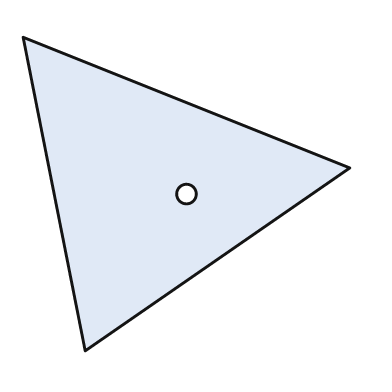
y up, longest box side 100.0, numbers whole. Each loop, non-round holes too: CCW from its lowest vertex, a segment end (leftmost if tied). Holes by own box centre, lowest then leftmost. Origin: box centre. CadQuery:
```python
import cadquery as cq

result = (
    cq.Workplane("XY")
    .moveTo(-31.0, -48.0)
    .lineTo(50.0, 8.0)
    .lineTo(-50.0, 48.0)
    .close()
    .moveTo(0.0, 0.0)
    .circle(3.0)
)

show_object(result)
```